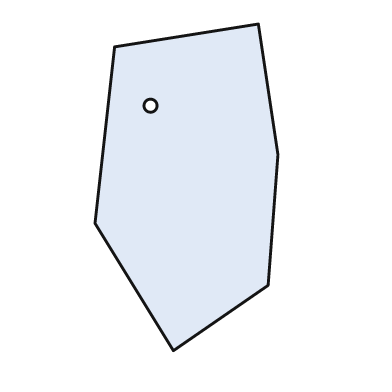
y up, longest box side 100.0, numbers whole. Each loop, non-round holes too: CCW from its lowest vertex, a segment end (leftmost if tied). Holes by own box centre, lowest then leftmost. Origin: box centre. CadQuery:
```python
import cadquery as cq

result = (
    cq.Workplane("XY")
    .moveTo(-4.0, -50.0)
    .lineTo(25.0, -30.0)
    .lineTo(28.0, 10.0)
    .lineTo(22.0, 50.0)
    .lineTo(-22.0, 43.0)
    .lineTo(-28.0, -11.0)
    .close()
    .moveTo(-11.0, 25.0)
    .circle(2.0)
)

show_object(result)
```